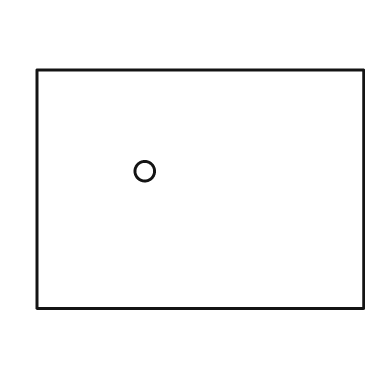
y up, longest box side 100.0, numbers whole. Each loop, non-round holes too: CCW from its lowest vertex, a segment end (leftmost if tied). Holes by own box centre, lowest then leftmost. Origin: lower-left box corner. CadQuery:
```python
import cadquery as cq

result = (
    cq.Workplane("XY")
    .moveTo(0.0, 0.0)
    .lineTo(100.0, 0.0)
    .lineTo(100.0, 73.0)
    .lineTo(0.0, 73.0)
    .close()
    .moveTo(33.0, 42.0)
    .circle(3.0)
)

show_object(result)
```